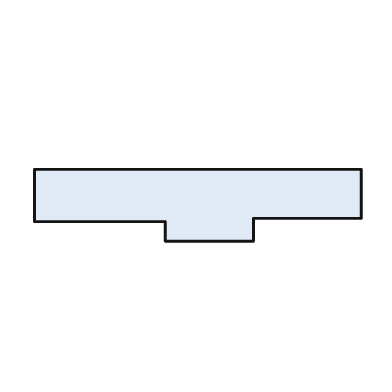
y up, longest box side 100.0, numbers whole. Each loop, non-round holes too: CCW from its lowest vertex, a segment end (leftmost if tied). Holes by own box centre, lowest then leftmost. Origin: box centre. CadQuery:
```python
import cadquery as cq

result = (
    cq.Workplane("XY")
    .moveTo(-10.0, -11.0)
    .lineTo(17.0, -11.0)
    .lineTo(17.0, -4.0)
    .lineTo(50.0, -4.0)
    .lineTo(50.0, 11.0)
    .lineTo(-50.0, 11.0)
    .lineTo(-50.0, -5.0)
    .lineTo(-10.0, -5.0)
    .close()
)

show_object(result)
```